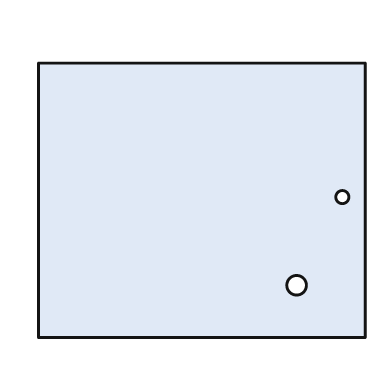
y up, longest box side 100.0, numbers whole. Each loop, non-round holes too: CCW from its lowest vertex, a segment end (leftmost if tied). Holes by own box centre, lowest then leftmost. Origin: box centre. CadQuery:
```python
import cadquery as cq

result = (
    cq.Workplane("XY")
    .moveTo(-50.0, -42.0)
    .lineTo(50.0, -42.0)
    .lineTo(50.0, 42.0)
    .lineTo(-50.0, 42.0)
    .close()
    .moveTo(29.0, -26.0)
    .circle(3.0)
    .moveTo(43.0, 1.0)
    .circle(2.0)
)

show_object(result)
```